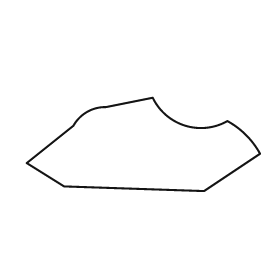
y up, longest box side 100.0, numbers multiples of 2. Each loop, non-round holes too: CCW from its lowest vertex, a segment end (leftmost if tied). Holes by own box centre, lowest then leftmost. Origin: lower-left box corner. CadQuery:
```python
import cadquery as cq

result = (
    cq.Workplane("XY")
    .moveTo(76.0, 0.0)
    .lineTo(100.0, 16.0)
    .threePointArc((94.0, 24.0), (86.0, 30.0))
    .threePointArc((68.0, 28.0), (54.0, 40.0))
    .lineTo(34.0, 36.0)
    .threePointArc((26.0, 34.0), (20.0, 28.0))
    .lineTo(0.0, 12.0)
    .lineTo(16.0, 2.0)
    .close()
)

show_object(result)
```